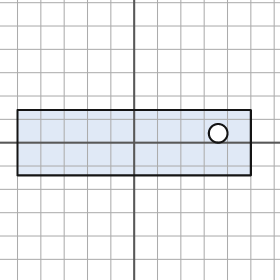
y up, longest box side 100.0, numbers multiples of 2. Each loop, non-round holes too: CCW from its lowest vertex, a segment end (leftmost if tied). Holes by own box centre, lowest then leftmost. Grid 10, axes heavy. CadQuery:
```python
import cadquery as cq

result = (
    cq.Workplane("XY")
    .moveTo(-50.0, -14.0)
    .lineTo(50.0, -14.0)
    .lineTo(50.0, 14.0)
    .lineTo(-50.0, 14.0)
    .close()
    .moveTo(36.0, 4.0)
    .circle(4.0)
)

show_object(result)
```